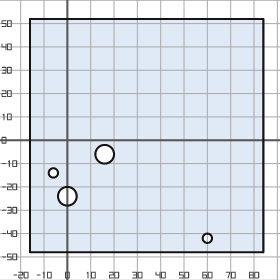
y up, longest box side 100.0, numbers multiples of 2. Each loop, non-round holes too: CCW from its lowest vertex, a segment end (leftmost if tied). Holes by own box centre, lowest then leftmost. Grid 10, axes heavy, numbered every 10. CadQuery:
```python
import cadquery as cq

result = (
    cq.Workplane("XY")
    .moveTo(-16.0, -48.0)
    .lineTo(84.0, -48.0)
    .lineTo(84.0, 52.0)
    .lineTo(-16.0, 52.0)
    .close()
    .moveTo(60.0, -42.0)
    .circle(2.0)
    .moveTo(0.0, -24.0)
    .circle(4.0)
    .moveTo(-6.0, -14.0)
    .circle(2.0)
    .moveTo(16.0, -6.0)
    .circle(4.0)
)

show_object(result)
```